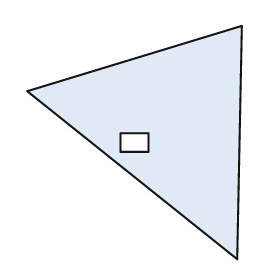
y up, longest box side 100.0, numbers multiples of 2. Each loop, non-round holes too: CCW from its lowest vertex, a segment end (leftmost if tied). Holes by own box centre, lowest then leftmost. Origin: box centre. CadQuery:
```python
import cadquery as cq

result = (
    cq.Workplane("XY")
    .moveTo(44.0, -50.0)
    .lineTo(46.0, 50.0)
    .lineTo(-46.0, 22.0)
    .close()
    .moveTo(-6.0, -4.0)
    .lineTo(6.0, -4.0)
    .lineTo(6.0, 4.0)
    .lineTo(-6.0, 4.0)
    .close()
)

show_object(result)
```